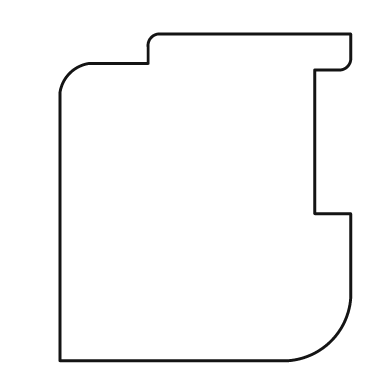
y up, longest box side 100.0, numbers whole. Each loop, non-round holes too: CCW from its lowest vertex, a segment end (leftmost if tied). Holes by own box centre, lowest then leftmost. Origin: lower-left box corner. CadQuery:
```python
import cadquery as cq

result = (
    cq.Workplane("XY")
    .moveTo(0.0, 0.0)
    .lineTo(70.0, 0.0)
    .threePointArc((83.0, 6.0), (89.0, 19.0))
    .lineTo(89.0, 45.0)
    .lineTo(78.0, 45.0)
    .lineTo(78.0, 89.0)
    .lineTo(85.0, 89.0)
    .threePointArc((88.0, 90.0), (89.0, 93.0))
    .lineTo(89.0, 100.0)
    .lineTo(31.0, 100.0)
    .threePointArc((28.0, 99.0), (27.0, 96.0))
    .lineTo(27.0, 91.0)
    .lineTo(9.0, 91.0)
    .threePointArc((3.0, 88.0), (0.0, 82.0))
    .close()
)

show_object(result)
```